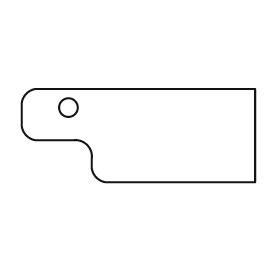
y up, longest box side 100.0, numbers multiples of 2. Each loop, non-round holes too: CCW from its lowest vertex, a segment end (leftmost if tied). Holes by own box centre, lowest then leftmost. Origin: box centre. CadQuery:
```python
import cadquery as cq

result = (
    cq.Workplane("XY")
    .moveTo(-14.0, -20.0)
    .lineTo(50.0, -20.0)
    .lineTo(50.0, 20.0)
    .lineTo(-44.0, 20.0)
    .threePointArc((-48.0, 18.0), (-50.0, 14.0))
    .lineTo(-50.0, 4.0)
    .threePointArc((-48.0, 0.0), (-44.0, -2.0))
    .lineTo(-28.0, -2.0)
    .threePointArc((-22.0, -4.0), (-20.0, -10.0))
    .lineTo(-20.0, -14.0)
    .threePointArc((-18.0, -18.0), (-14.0, -20.0))
    .close()
    .moveTo(-30.0, 12.0)
    .circle(4.0)
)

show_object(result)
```